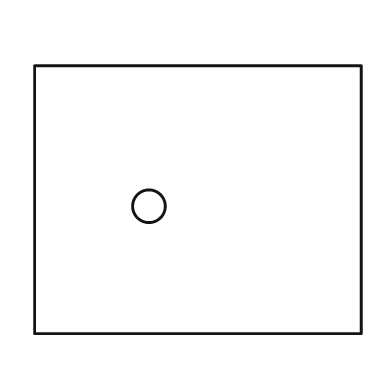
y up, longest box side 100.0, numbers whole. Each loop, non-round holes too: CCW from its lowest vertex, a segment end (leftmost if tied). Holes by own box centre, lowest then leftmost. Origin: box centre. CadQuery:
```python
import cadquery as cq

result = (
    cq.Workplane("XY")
    .moveTo(-50.0, -41.0)
    .lineTo(50.0, -41.0)
    .lineTo(50.0, 41.0)
    .lineTo(-50.0, 41.0)
    .close()
    .moveTo(-15.0, -2.0)
    .circle(5.0)
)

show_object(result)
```